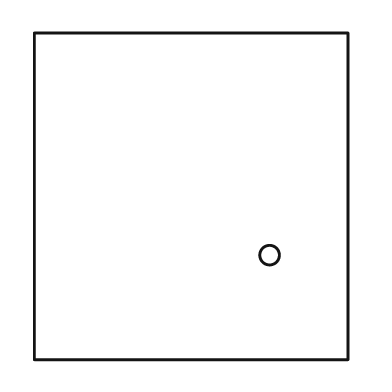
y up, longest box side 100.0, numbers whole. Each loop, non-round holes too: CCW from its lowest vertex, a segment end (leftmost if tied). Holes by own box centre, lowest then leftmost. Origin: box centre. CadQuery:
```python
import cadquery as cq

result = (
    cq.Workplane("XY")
    .moveTo(-48.0, -50.0)
    .lineTo(48.0, -50.0)
    .lineTo(48.0, 50.0)
    .lineTo(-48.0, 50.0)
    .close()
    .moveTo(24.0, -18.0)
    .circle(3.0)
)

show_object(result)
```